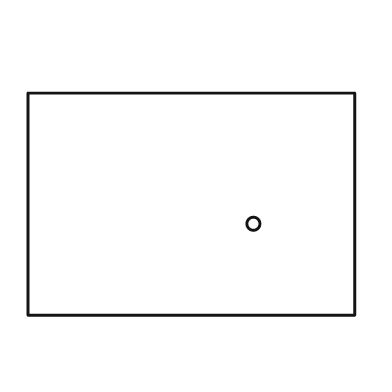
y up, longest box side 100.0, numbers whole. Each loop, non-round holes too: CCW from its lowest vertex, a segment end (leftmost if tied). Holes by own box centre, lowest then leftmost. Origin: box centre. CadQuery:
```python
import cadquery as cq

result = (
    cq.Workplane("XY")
    .moveTo(-50.0, -34.0)
    .lineTo(50.0, -34.0)
    .lineTo(50.0, 34.0)
    .lineTo(-50.0, 34.0)
    .close()
    .moveTo(19.0, -6.0)
    .circle(2.0)
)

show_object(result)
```